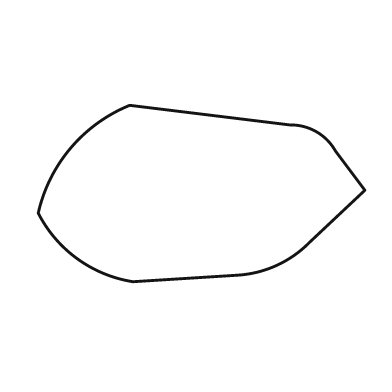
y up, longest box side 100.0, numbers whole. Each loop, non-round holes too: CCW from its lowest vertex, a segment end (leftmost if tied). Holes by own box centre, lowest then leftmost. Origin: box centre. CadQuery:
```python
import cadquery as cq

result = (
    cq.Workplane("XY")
    .moveTo(-21.0, -27.0)
    .lineTo(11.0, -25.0)
    .threePointArc((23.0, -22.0), (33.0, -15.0))
    .lineTo(50.0, 1.0)
    .lineTo(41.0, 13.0)
    .threePointArc((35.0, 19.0), (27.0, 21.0))
    .lineTo(-22.0, 27.0)
    .threePointArc((-40.0, 14.0), (-50.0, -6.0))
    .threePointArc((-38.0, -20.0), (-21.0, -27.0))
    .close()
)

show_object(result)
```